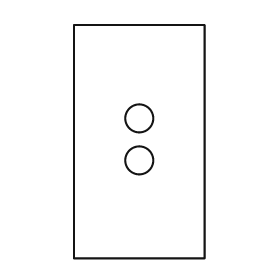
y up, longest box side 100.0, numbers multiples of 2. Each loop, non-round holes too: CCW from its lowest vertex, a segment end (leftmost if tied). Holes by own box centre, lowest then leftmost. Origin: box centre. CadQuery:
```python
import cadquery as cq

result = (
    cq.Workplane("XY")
    .moveTo(-28.0, -50.0)
    .lineTo(28.0, -50.0)
    .lineTo(28.0, 50.0)
    .lineTo(-28.0, 50.0)
    .close()
    .moveTo(0.0, -8.0)
    .circle(6.0)
    .moveTo(0.0, 10.0)
    .circle(6.0)
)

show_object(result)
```